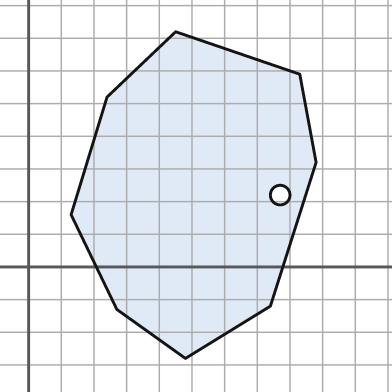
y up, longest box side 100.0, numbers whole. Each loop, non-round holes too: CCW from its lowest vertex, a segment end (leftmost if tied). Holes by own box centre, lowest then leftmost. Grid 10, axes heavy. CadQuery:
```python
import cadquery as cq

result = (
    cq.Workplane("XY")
    .moveTo(48.0, -28.0)
    .lineTo(74.0, -12.0)
    .lineTo(88.0, 32.0)
    .lineTo(83.0, 59.0)
    .lineTo(45.0, 72.0)
    .lineTo(24.0, 52.0)
    .lineTo(13.0, 16.0)
    .lineTo(27.0, -13.0)
    .close()
    .moveTo(77.0, 22.0)
    .circle(3.0)
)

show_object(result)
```